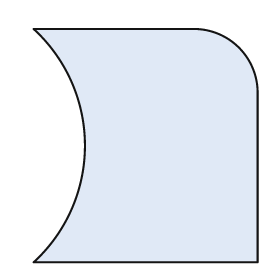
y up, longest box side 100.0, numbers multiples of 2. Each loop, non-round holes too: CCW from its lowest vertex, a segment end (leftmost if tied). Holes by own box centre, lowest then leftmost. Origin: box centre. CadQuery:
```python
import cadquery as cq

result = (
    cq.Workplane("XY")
    .moveTo(-48.0, -50.0)
    .lineTo(48.0, -50.0)
    .lineTo(48.0, 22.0)
    .threePointArc((40.0, 42.0), (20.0, 50.0))
    .lineTo(-48.0, 50.0)
    .threePointArc((-26.0, 0.0), (-48.0, -50.0))
    .close()
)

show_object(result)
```